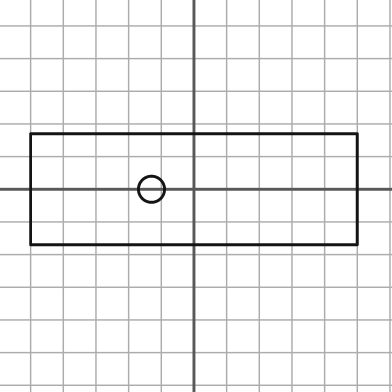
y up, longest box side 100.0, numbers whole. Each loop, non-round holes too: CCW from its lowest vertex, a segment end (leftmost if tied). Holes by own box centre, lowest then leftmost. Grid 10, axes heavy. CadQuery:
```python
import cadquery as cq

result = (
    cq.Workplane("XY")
    .moveTo(-50.0, -17.0)
    .lineTo(50.0, -17.0)
    .lineTo(50.0, 17.0)
    .lineTo(-50.0, 17.0)
    .close()
    .moveTo(-13.0, 0.0)
    .circle(4.0)
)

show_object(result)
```